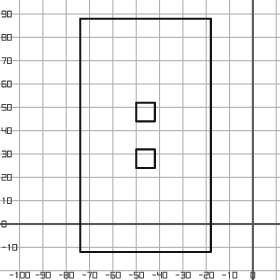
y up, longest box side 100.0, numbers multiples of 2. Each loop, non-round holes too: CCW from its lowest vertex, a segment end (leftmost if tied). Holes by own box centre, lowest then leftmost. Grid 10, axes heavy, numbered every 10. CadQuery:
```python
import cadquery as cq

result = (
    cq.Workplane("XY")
    .moveTo(-74.0, -12.0)
    .lineTo(-18.0, -12.0)
    .lineTo(-18.0, 88.0)
    .lineTo(-74.0, 88.0)
    .close()
    .moveTo(-50.0, 24.0)
    .lineTo(-42.0, 24.0)
    .lineTo(-42.0, 32.0)
    .lineTo(-50.0, 32.0)
    .close()
    .moveTo(-50.0, 44.0)
    .lineTo(-42.0, 44.0)
    .lineTo(-42.0, 52.0)
    .lineTo(-50.0, 52.0)
    .close()
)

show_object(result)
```